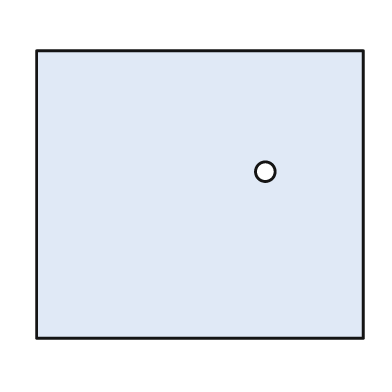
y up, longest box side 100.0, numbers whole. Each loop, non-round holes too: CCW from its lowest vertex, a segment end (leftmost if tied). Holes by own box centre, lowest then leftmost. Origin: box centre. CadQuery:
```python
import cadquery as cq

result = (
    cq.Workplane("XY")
    .moveTo(-50.0, -44.0)
    .lineTo(50.0, -44.0)
    .lineTo(50.0, 44.0)
    .lineTo(-50.0, 44.0)
    .close()
    .moveTo(20.0, 7.0)
    .circle(3.0)
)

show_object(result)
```